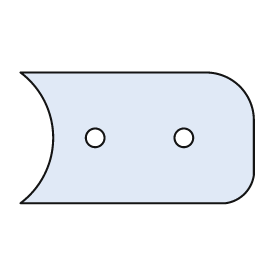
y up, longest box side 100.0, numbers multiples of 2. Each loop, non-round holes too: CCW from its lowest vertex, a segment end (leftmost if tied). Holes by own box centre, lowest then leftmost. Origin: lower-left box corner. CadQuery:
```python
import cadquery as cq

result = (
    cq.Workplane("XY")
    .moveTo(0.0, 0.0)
    .lineTo(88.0, 0.0)
    .threePointArc((96.0, 4.0), (100.0, 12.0))
    .lineTo(100.0, 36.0)
    .threePointArc((94.0, 50.0), (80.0, 56.0))
    .lineTo(0.0, 56.0)
    .threePointArc((14.0, 28.0), (0.0, 0.0))
    .close()
    .moveTo(32.0, 28.0)
    .circle(4.0)
    .moveTo(70.0, 28.0)
    .circle(4.0)
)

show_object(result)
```